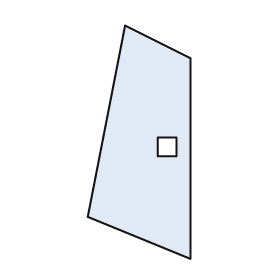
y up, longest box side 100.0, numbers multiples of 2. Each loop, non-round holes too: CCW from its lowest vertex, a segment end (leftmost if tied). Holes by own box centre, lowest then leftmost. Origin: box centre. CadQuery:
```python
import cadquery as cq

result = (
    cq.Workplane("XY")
    .moveTo(22.0, -50.0)
    .lineTo(22.0, 36.0)
    .lineTo(-6.0, 50.0)
    .lineTo(-22.0, -32.0)
    .close()
    .moveTo(8.0, -6.0)
    .lineTo(16.0, -6.0)
    .lineTo(16.0, 2.0)
    .lineTo(8.0, 2.0)
    .close()
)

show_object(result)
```